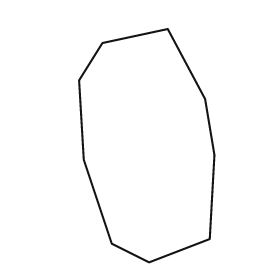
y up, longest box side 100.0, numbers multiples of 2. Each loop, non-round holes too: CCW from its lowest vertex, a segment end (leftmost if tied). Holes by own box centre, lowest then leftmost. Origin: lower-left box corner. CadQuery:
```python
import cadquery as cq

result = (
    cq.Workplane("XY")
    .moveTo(30.0, 0.0)
    .lineTo(56.0, 10.0)
    .lineTo(58.0, 46.0)
    .lineTo(54.0, 70.0)
    .lineTo(38.0, 100.0)
    .lineTo(10.0, 94.0)
    .lineTo(0.0, 78.0)
    .lineTo(2.0, 44.0)
    .lineTo(14.0, 8.0)
    .close()
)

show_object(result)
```